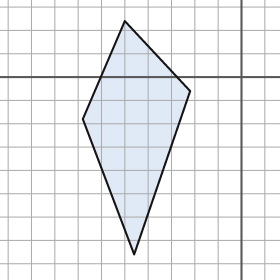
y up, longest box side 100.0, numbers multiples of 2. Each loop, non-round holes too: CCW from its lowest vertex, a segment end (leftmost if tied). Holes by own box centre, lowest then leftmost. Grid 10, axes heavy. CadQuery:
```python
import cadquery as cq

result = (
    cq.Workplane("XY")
    .moveTo(-46.0, -76.0)
    .lineTo(-22.0, -6.0)
    .lineTo(-50.0, 24.0)
    .lineTo(-68.0, -18.0)
    .close()
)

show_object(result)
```